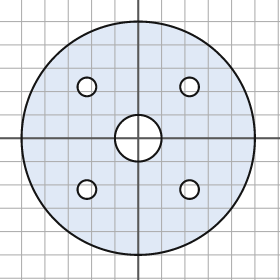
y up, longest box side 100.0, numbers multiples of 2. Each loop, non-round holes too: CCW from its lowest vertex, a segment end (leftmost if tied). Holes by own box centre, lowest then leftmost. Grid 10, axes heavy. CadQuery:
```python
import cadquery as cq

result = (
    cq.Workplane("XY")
    .moveTo(0.0, 0.0)
    .circle(50.0)
    .moveTo(-22.0, -22.0)
    .circle(4.0)
    .moveTo(22.0, -22.0)
    .circle(4.0)
    .moveTo(0.0, 0.0)
    .circle(10.0)
    .moveTo(-22.0, 22.0)
    .circle(4.0)
    .moveTo(22.0, 22.0)
    .circle(4.0)
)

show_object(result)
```